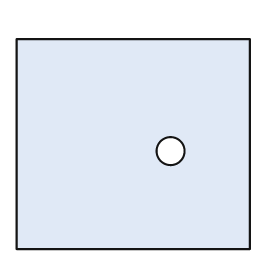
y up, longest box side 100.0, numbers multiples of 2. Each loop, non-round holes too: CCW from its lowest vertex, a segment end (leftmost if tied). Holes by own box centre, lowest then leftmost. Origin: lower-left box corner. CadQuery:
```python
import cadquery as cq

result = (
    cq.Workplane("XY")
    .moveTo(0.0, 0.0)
    .lineTo(100.0, 0.0)
    .lineTo(100.0, 90.0)
    .lineTo(0.0, 90.0)
    .close()
    .moveTo(66.0, 42.0)
    .circle(6.0)
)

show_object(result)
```